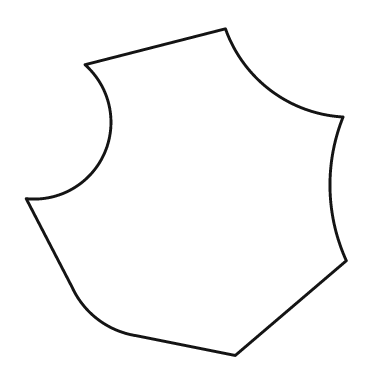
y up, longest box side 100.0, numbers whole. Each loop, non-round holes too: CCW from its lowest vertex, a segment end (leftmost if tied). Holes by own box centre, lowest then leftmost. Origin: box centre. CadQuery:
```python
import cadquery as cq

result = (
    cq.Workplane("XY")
    .moveTo(15.0, -50.0)
    .lineTo(49.0, -21.0)
    .threePointArc((44.0, 1.0), (48.0, 23.0))
    .threePointArc((26.0, 31.0), (12.0, 50.0))
    .lineTo(-31.0, 39.0)
    .threePointArc((-25.0, 12.0), (-49.0, -2.0))
    .lineTo(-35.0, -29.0)
    .threePointArc((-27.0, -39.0), (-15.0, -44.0))
    .close()
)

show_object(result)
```